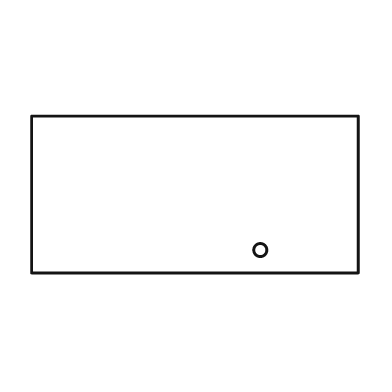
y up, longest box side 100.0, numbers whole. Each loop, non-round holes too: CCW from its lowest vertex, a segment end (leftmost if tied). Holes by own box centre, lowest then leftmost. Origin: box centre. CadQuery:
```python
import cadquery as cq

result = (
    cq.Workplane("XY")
    .moveTo(-50.0, -24.0)
    .lineTo(50.0, -24.0)
    .lineTo(50.0, 24.0)
    .lineTo(-50.0, 24.0)
    .close()
    .moveTo(20.0, -17.0)
    .circle(2.0)
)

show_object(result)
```